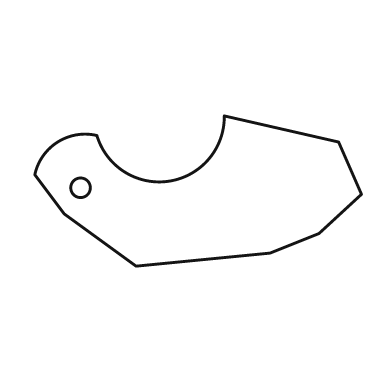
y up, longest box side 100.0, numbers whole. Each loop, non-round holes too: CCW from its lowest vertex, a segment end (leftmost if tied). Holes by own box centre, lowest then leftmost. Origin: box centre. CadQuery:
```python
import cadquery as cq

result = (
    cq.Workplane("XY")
    .moveTo(-19.0, -23.0)
    .lineTo(22.0, -19.0)
    .lineTo(37.0, -13.0)
    .lineTo(50.0, -1.0)
    .lineTo(43.0, 15.0)
    .lineTo(8.0, 23.0)
    .threePointArc((-9.0, 3.0), (-31.0, 17.0))
    .threePointArc((-43.0, 15.0), (-50.0, 5.0))
    .lineTo(-41.0, -7.0)
    .close()
    .moveTo(-36.0, 1.0)
    .circle(3.0)
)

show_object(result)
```